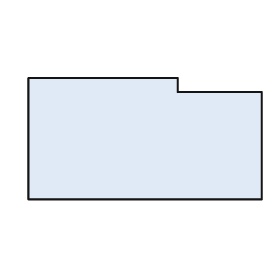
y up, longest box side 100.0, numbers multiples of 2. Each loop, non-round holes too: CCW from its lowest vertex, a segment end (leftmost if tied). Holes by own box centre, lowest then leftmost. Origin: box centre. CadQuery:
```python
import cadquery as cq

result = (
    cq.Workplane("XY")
    .moveTo(-50.0, -26.0)
    .lineTo(50.0, -26.0)
    .lineTo(50.0, 20.0)
    .lineTo(14.0, 20.0)
    .lineTo(14.0, 26.0)
    .lineTo(-50.0, 26.0)
    .close()
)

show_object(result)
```